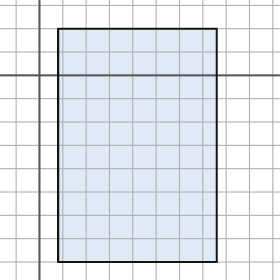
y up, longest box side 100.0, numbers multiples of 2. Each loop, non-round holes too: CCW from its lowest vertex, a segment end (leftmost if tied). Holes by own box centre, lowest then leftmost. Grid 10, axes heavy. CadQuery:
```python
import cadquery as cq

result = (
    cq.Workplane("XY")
    .moveTo(8.0, -80.0)
    .lineTo(76.0, -80.0)
    .lineTo(76.0, 20.0)
    .lineTo(8.0, 20.0)
    .close()
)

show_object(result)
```